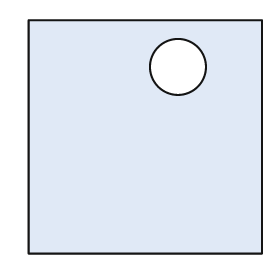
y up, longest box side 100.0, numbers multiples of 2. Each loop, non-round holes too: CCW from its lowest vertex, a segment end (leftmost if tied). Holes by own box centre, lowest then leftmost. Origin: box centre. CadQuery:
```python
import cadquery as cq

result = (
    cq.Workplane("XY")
    .moveTo(-50.0, -50.0)
    .lineTo(50.0, -50.0)
    .lineTo(50.0, 50.0)
    .lineTo(-50.0, 50.0)
    .close()
    .moveTo(14.0, 30.0)
    .circle(12.0)
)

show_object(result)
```